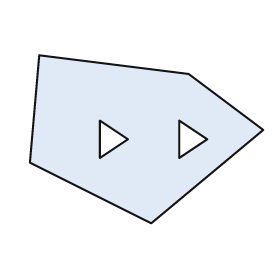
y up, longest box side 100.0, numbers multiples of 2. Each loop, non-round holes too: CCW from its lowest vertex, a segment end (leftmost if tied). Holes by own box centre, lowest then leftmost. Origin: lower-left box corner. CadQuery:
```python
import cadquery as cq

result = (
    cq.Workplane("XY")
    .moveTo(52.0, 0.0)
    .lineTo(100.0, 40.0)
    .lineTo(68.0, 64.0)
    .lineTo(4.0, 72.0)
    .lineTo(0.0, 26.0)
    .close()
    .moveTo(30.0, 28.0)
    .lineTo(42.0, 36.0)
    .lineTo(30.0, 44.0)
    .close()
    .moveTo(64.0, 28.0)
    .lineTo(76.0, 36.0)
    .lineTo(64.0, 44.0)
    .close()
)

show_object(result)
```